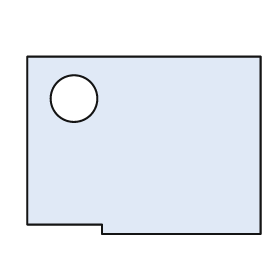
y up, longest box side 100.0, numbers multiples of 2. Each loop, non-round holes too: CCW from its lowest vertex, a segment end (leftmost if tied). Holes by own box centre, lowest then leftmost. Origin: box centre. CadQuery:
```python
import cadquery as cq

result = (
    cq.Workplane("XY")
    .moveTo(-18.0, -38.0)
    .lineTo(50.0, -38.0)
    .lineTo(50.0, 38.0)
    .lineTo(-50.0, 38.0)
    .lineTo(-50.0, -34.0)
    .lineTo(-18.0, -34.0)
    .close()
    .moveTo(-30.0, 20.0)
    .circle(10.0)
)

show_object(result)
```